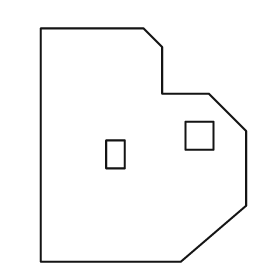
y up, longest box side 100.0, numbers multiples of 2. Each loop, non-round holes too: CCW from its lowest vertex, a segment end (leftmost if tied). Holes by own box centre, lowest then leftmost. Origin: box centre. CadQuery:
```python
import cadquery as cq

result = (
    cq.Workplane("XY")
    .moveTo(-44.0, -50.0)
    .lineTo(16.0, -50.0)
    .lineTo(44.0, -26.0)
    .lineTo(44.0, 6.0)
    .lineTo(28.0, 22.0)
    .lineTo(8.0, 22.0)
    .lineTo(8.0, 42.0)
    .lineTo(0.0, 50.0)
    .lineTo(-44.0, 50.0)
    .close()
    .moveTo(-16.0, -10.0)
    .lineTo(-8.0, -10.0)
    .lineTo(-8.0, 2.0)
    .lineTo(-16.0, 2.0)
    .close()
    .moveTo(18.0, -2.0)
    .lineTo(30.0, -2.0)
    .lineTo(30.0, 10.0)
    .lineTo(18.0, 10.0)
    .close()
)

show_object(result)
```